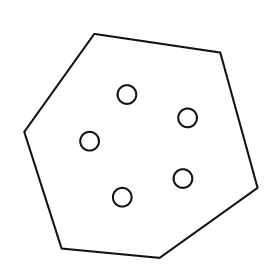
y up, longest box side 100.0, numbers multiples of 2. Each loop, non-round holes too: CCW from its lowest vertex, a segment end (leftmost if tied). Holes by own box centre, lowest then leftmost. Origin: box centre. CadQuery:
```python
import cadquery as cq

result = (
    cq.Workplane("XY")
    .moveTo(8.0, -48.0)
    .lineTo(50.0, -18.0)
    .lineTo(34.0, 40.0)
    .lineTo(-20.0, 48.0)
    .lineTo(-50.0, 6.0)
    .lineTo(-34.0, -44.0)
    .close()
    .moveTo(-8.0, -22.0)
    .circle(4.0)
    .moveTo(18.0, -14.0)
    .circle(4.0)
    .moveTo(-22.0, 2.0)
    .circle(4.0)
    .moveTo(20.0, 12.0)
    .circle(4.0)
    .moveTo(-6.0, 22.0)
    .circle(4.0)
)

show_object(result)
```